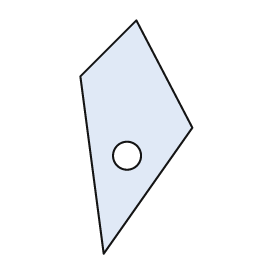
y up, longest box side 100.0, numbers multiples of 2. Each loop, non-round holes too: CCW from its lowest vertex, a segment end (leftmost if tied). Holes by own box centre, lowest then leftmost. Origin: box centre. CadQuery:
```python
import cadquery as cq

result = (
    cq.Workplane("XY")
    .moveTo(-14.0, -50.0)
    .lineTo(24.0, 4.0)
    .lineTo(0.0, 50.0)
    .lineTo(-24.0, 26.0)
    .close()
    .moveTo(-4.0, -8.0)
    .circle(6.0)
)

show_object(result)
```